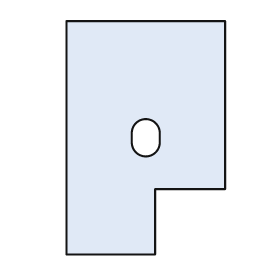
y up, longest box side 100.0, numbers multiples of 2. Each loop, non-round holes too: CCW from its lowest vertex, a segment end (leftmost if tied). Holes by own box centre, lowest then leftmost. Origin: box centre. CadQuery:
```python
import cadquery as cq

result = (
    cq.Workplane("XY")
    .moveTo(-34.0, -50.0)
    .lineTo(4.0, -50.0)
    .lineTo(4.0, -22.0)
    .lineTo(34.0, -22.0)
    .lineTo(34.0, 50.0)
    .lineTo(-34.0, 50.0)
    .close()
    .moveTo(-6.0, -2.0)
    .threePointArc((0.0, -8.0), (6.0, -2.0))
    .lineTo(6.0, 2.0)
    .threePointArc((0.0, 8.0), (-6.0, 2.0))
    .close()
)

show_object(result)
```